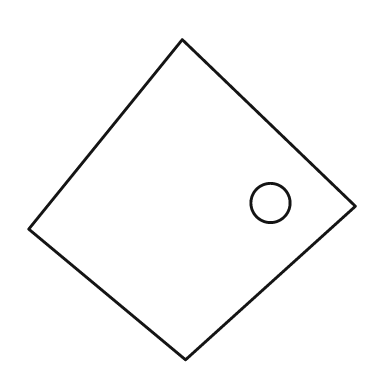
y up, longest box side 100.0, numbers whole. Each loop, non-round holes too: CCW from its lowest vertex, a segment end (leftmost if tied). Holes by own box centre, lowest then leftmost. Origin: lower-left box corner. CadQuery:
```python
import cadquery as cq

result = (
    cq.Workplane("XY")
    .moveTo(48.0, 0.0)
    .lineTo(100.0, 47.0)
    .lineTo(47.0, 98.0)
    .lineTo(0.0, 40.0)
    .close()
    .moveTo(74.0, 48.0)
    .circle(6.0)
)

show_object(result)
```